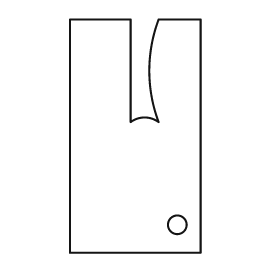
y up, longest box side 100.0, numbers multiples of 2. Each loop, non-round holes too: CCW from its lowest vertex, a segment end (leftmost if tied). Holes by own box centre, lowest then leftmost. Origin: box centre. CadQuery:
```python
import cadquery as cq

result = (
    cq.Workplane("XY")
    .moveTo(-28.0, -50.0)
    .lineTo(28.0, -50.0)
    .lineTo(28.0, 50.0)
    .lineTo(10.0, 50.0)
    .threePointArc((6.0, 28.0), (10.0, 6.0))
    .threePointArc((4.0, 8.0), (-2.0, 6.0))
    .lineTo(-2.0, 50.0)
    .lineTo(-28.0, 50.0)
    .close()
    .moveTo(18.0, -38.0)
    .circle(4.0)
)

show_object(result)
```